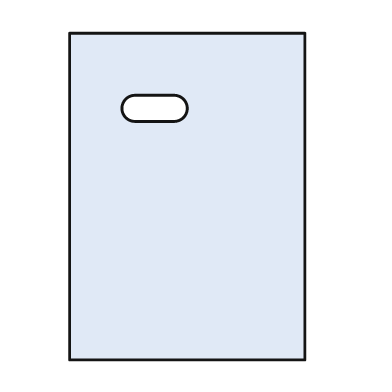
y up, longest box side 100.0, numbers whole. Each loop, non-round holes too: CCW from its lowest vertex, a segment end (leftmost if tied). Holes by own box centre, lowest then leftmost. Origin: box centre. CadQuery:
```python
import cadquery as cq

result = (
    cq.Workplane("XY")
    .moveTo(-36.0, -50.0)
    .lineTo(36.0, -50.0)
    .lineTo(36.0, 50.0)
    .lineTo(-36.0, 50.0)
    .close()
    .moveTo(-16.0, 23.0)
    .lineTo(-4.0, 23.0)
    .threePointArc((0.0, 27.0), (-4.0, 31.0))
    .lineTo(-16.0, 31.0)
    .threePointArc((-20.0, 27.0), (-16.0, 23.0))
    .close()
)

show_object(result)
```